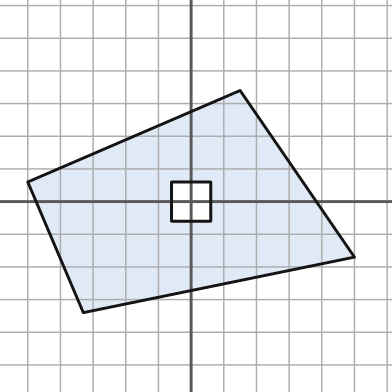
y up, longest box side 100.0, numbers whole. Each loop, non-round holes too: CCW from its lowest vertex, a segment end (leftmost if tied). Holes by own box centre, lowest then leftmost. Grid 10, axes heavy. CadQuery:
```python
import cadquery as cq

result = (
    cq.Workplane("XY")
    .moveTo(-33.0, -34.0)
    .lineTo(50.0, -17.0)
    .lineTo(15.0, 34.0)
    .lineTo(-50.0, 6.0)
    .close()
    .moveTo(-6.0, -6.0)
    .lineTo(6.0, -6.0)
    .lineTo(6.0, 6.0)
    .lineTo(-6.0, 6.0)
    .close()
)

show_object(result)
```